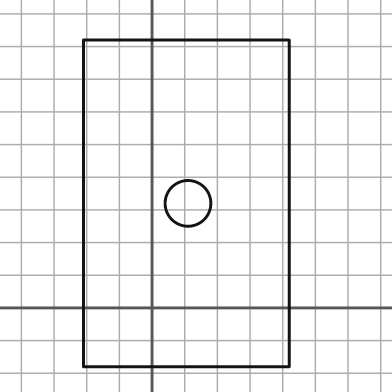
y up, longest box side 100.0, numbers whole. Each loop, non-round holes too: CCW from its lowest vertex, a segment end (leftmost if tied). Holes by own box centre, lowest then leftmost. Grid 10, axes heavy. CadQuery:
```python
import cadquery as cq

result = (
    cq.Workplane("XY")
    .moveTo(-21.0, -18.0)
    .lineTo(42.0, -18.0)
    .lineTo(42.0, 82.0)
    .lineTo(-21.0, 82.0)
    .close()
    .moveTo(11.0, 32.0)
    .circle(7.0)
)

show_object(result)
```